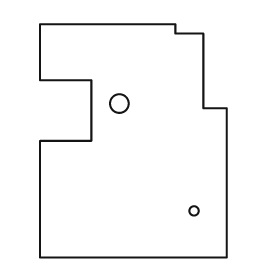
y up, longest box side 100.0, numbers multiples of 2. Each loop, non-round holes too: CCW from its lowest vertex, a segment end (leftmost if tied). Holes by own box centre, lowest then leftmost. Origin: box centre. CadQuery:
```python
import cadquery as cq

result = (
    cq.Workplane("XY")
    .moveTo(-40.0, -50.0)
    .lineTo(40.0, -50.0)
    .lineTo(40.0, 14.0)
    .lineTo(30.0, 14.0)
    .lineTo(30.0, 46.0)
    .lineTo(18.0, 46.0)
    .lineTo(18.0, 50.0)
    .lineTo(-40.0, 50.0)
    .lineTo(-40.0, 26.0)
    .lineTo(-18.0, 26.0)
    .lineTo(-18.0, 0.0)
    .lineTo(-40.0, 0.0)
    .close()
    .moveTo(26.0, -30.0)
    .circle(2.0)
    .moveTo(-6.0, 16.0)
    .circle(4.0)
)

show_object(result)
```